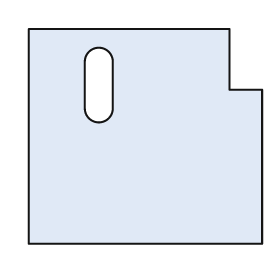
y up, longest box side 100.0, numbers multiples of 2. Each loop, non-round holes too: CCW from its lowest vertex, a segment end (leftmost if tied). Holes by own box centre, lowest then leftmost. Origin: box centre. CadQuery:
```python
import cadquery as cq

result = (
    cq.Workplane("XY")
    .moveTo(-50.0, -46.0)
    .lineTo(50.0, -46.0)
    .lineTo(50.0, 20.0)
    .lineTo(36.0, 20.0)
    .lineTo(36.0, 46.0)
    .lineTo(-50.0, 46.0)
    .close()
    .moveTo(-26.0, 12.0)
    .threePointArc((-20.0, 6.0), (-14.0, 12.0))
    .lineTo(-14.0, 32.0)
    .threePointArc((-20.0, 38.0), (-26.0, 32.0))
    .close()
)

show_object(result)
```